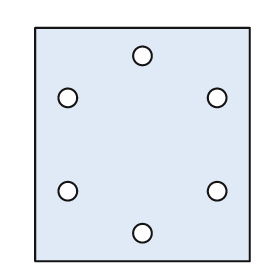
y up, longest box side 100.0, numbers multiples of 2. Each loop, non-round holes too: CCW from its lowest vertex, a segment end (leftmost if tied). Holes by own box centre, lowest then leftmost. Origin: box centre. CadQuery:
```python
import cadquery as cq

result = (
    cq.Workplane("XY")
    .moveTo(-46.0, -50.0)
    .lineTo(46.0, -50.0)
    .lineTo(46.0, 50.0)
    .lineTo(-46.0, 50.0)
    .close()
    .moveTo(0.0, -38.0)
    .circle(4.0)
    .moveTo(-32.0, -20.0)
    .circle(4.0)
    .moveTo(32.0, -20.0)
    .circle(4.0)
    .moveTo(-32.0, 20.0)
    .circle(4.0)
    .moveTo(32.0, 20.0)
    .circle(4.0)
    .moveTo(0.0, 38.0)
    .circle(4.0)
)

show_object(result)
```